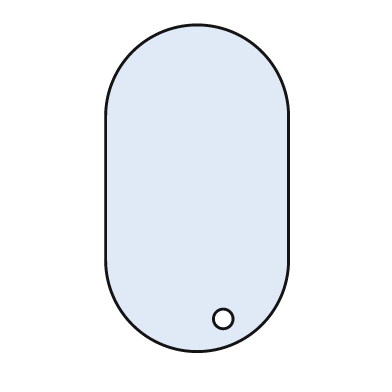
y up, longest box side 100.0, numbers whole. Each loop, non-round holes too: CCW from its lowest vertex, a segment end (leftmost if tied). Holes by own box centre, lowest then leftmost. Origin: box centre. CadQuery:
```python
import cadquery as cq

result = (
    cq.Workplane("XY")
    .moveTo(-28.0, -22.0)
    .threePointArc((0.0, -50.0), (28.0, -22.0))
    .lineTo(28.0, 22.0)
    .threePointArc((0.0, 50.0), (-28.0, 22.0))
    .close()
    .moveTo(8.0, -40.0)
    .circle(3.0)
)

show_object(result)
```